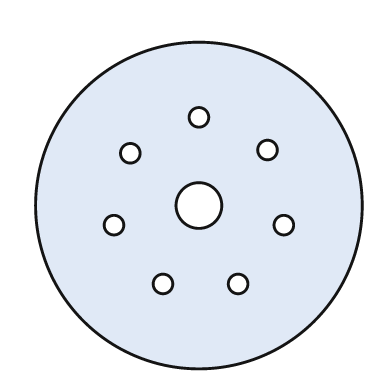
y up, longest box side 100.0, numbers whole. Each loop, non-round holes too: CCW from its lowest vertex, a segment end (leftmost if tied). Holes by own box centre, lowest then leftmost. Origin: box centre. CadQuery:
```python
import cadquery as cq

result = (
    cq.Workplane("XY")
    .moveTo(0.0, 0.0)
    .circle(50.0)
    .moveTo(-11.0, -24.0)
    .circle(3.0)
    .moveTo(12.0, -24.0)
    .circle(3.0)
    .moveTo(-26.0, -6.0)
    .circle(3.0)
    .moveTo(26.0, -6.0)
    .circle(3.0)
    .moveTo(0.0, 0.0)
    .circle(7.0)
    .moveTo(-21.0, 16.0)
    .circle(3.0)
    .moveTo(21.0, 17.0)
    .circle(3.0)
    .moveTo(0.0, 27.0)
    .circle(3.0)
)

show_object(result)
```